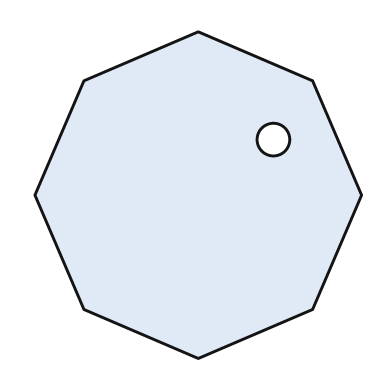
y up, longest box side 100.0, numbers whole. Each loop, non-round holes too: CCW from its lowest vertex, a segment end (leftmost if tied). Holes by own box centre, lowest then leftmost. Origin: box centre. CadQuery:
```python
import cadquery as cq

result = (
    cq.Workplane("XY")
    .moveTo(0.0, -50.0)
    .lineTo(35.0, -35.0)
    .lineTo(50.0, 0.0)
    .lineTo(35.0, 35.0)
    .lineTo(0.0, 50.0)
    .lineTo(-35.0, 35.0)
    .lineTo(-50.0, 0.0)
    .lineTo(-35.0, -35.0)
    .close()
    .moveTo(23.0, 17.0)
    .circle(5.0)
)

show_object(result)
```